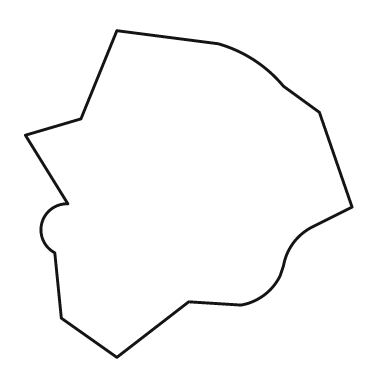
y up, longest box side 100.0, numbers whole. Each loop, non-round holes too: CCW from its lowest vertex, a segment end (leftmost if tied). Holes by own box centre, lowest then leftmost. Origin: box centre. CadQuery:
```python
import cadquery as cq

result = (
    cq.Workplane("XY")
    .moveTo(-22.0, -50.0)
    .lineTo(0.0, -33.0)
    .lineTo(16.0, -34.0)
    .threePointArc((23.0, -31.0), (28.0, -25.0))
    .lineTo(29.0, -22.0)
    .threePointArc((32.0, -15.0), (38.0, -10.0))
    .lineTo(50.0, -4.0)
    .lineTo(40.0, 25.0)
    .lineTo(29.0, 33.0)
    .threePointArc((20.0, 41.0), (9.0, 46.0))
    .lineTo(-22.0, 50.0)
    .lineTo(-33.0, 23.0)
    .lineTo(-50.0, 18.0)
    .lineTo(-37.0, -3.0)
    .threePointArc((-45.0, -9.0), (-41.0, -18.0))
    .lineTo(-39.0, -38.0)
    .close()
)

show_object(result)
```